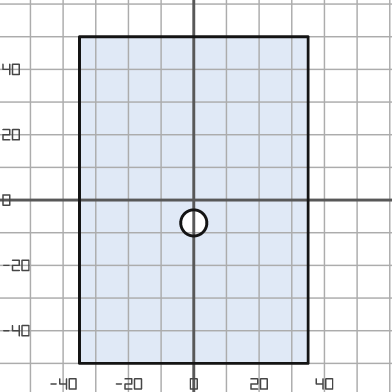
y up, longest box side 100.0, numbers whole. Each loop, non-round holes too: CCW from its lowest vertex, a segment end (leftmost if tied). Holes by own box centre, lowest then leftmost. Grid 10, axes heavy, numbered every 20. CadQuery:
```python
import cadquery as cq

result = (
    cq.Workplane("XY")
    .moveTo(-35.0, -50.0)
    .lineTo(35.0, -50.0)
    .lineTo(35.0, 50.0)
    .lineTo(-35.0, 50.0)
    .close()
    .moveTo(0.0, -7.0)
    .circle(4.0)
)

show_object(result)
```